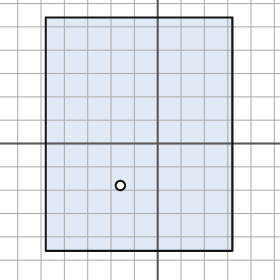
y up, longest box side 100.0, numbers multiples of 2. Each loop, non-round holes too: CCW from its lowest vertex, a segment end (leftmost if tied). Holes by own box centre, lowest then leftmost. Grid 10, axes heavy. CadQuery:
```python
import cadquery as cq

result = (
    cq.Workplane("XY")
    .moveTo(-48.0, -46.0)
    .lineTo(32.0, -46.0)
    .lineTo(32.0, 54.0)
    .lineTo(-48.0, 54.0)
    .close()
    .moveTo(-16.0, -18.0)
    .circle(2.0)
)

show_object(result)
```